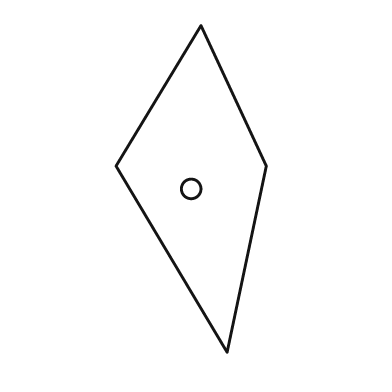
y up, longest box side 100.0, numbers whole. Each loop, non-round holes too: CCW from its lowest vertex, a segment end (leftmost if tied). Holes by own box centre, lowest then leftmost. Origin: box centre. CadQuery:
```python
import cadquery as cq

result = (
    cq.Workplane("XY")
    .moveTo(11.0, -50.0)
    .lineTo(23.0, 7.0)
    .lineTo(3.0, 50.0)
    .lineTo(-23.0, 7.0)
    .close()
    .moveTo(0.0, 0.0)
    .circle(3.0)
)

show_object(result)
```